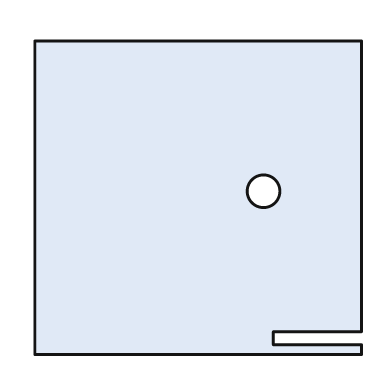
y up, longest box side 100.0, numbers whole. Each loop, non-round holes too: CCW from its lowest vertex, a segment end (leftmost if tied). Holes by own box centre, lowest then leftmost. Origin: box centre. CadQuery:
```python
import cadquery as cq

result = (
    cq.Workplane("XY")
    .moveTo(-50.0, -48.0)
    .lineTo(50.0, -48.0)
    .lineTo(50.0, -45.0)
    .lineTo(23.0, -45.0)
    .lineTo(23.0, -41.0)
    .lineTo(50.0, -41.0)
    .lineTo(50.0, 48.0)
    .lineTo(-50.0, 48.0)
    .close()
    .moveTo(20.0, 2.0)
    .circle(5.0)
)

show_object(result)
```